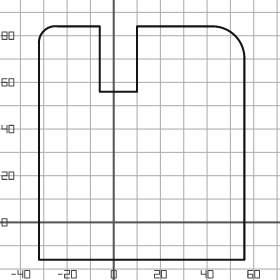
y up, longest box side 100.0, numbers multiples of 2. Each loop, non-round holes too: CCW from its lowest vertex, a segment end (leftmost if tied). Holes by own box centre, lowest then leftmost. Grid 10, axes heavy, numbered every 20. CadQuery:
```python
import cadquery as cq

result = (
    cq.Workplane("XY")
    .moveTo(-32.0, -16.0)
    .lineTo(56.0, -16.0)
    .lineTo(56.0, 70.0)
    .threePointArc((52.0, 80.0), (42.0, 84.0))
    .lineTo(10.0, 84.0)
    .lineTo(10.0, 56.0)
    .lineTo(-6.0, 56.0)
    .lineTo(-6.0, 84.0)
    .lineTo(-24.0, 84.0)
    .threePointArc((-30.0, 82.0), (-32.0, 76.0))
    .close()
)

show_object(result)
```